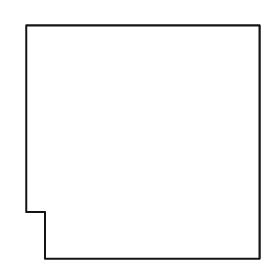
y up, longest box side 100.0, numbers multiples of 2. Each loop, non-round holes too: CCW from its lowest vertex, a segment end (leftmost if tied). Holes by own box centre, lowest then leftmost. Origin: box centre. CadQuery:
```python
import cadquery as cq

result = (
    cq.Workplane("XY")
    .moveTo(-42.0, -50.0)
    .lineTo(50.0, -50.0)
    .lineTo(50.0, 50.0)
    .lineTo(-50.0, 50.0)
    .lineTo(-50.0, -30.0)
    .lineTo(-42.0, -30.0)
    .close()
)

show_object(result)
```